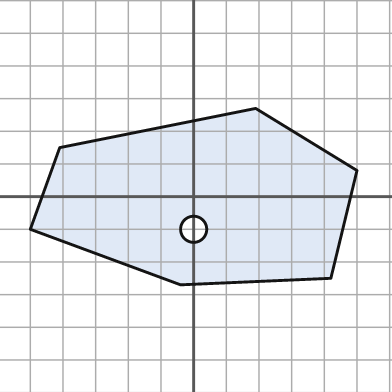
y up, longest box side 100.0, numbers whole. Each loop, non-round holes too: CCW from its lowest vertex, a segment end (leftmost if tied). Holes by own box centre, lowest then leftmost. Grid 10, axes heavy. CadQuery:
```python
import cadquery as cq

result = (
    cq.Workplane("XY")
    .moveTo(-4.0, -27.0)
    .lineTo(42.0, -25.0)
    .lineTo(50.0, 8.0)
    .lineTo(19.0, 27.0)
    .lineTo(-41.0, 15.0)
    .lineTo(-50.0, -10.0)
    .close()
    .moveTo(0.0, -10.0)
    .circle(4.0)
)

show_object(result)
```